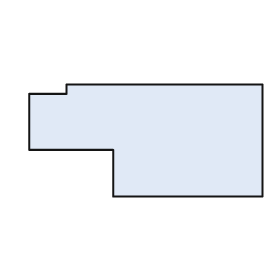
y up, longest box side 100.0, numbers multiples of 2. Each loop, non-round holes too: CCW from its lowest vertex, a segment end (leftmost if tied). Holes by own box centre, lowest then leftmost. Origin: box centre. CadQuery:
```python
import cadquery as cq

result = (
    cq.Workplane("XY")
    .moveTo(-14.0, -24.0)
    .lineTo(50.0, -24.0)
    .lineTo(50.0, 24.0)
    .lineTo(-34.0, 24.0)
    .lineTo(-34.0, 20.0)
    .lineTo(-50.0, 20.0)
    .lineTo(-50.0, -4.0)
    .lineTo(-14.0, -4.0)
    .close()
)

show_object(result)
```